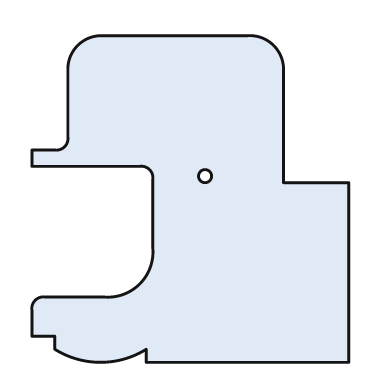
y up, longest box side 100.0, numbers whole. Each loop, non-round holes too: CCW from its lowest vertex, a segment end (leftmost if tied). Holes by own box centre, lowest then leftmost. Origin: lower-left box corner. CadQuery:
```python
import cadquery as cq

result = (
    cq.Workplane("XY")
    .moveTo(35.0, 0.0)
    .lineTo(97.0, 0.0)
    .lineTo(97.0, 55.0)
    .lineTo(77.0, 55.0)
    .lineTo(77.0, 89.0)
    .threePointArc((74.0, 97.0), (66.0, 100.0))
    .lineTo(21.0, 100.0)
    .threePointArc((14.0, 97.0), (11.0, 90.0))
    .lineTo(11.0, 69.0)
    .threePointArc((10.0, 66.0), (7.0, 65.0))
    .lineTo(0.0, 65.0)
    .lineTo(0.0, 60.0)
    .lineTo(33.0, 60.0)
    .threePointArc((36.0, 59.0), (37.0, 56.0))
    .lineTo(37.0, 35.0)
    .threePointArc((33.0, 24.0), (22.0, 20.0))
    .lineTo(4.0, 20.0)
    .threePointArc((1.0, 19.0), (0.0, 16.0))
    .lineTo(0.0, 8.0)
    .lineTo(7.0, 8.0)
    .lineTo(7.0, 4.0)
    .threePointArc((21.0, 0.0), (35.0, 4.0))
    .close()
    .moveTo(53.0, 57.0)
    .circle(2.0)
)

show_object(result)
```